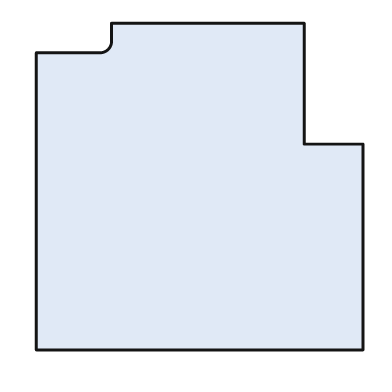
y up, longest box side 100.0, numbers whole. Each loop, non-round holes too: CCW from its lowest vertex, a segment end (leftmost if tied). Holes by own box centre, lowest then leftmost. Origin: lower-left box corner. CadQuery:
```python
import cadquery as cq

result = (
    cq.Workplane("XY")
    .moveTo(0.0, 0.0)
    .lineTo(100.0, 0.0)
    .lineTo(100.0, 63.0)
    .lineTo(82.0, 63.0)
    .lineTo(82.0, 100.0)
    .lineTo(23.0, 100.0)
    .lineTo(23.0, 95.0)
    .threePointArc((22.0, 92.0), (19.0, 91.0))
    .lineTo(0.0, 91.0)
    .close()
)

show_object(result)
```